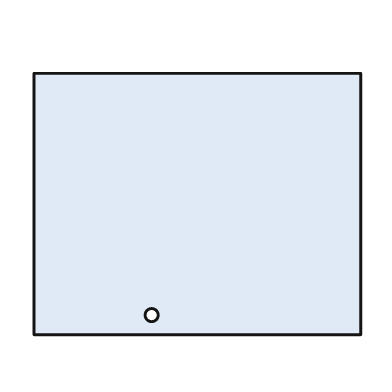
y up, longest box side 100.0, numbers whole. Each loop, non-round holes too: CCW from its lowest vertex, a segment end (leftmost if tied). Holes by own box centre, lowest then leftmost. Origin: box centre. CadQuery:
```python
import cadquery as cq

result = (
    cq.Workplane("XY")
    .moveTo(-50.0, -40.0)
    .lineTo(50.0, -40.0)
    .lineTo(50.0, 40.0)
    .lineTo(-50.0, 40.0)
    .close()
    .moveTo(-14.0, -34.0)
    .circle(2.0)
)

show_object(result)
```